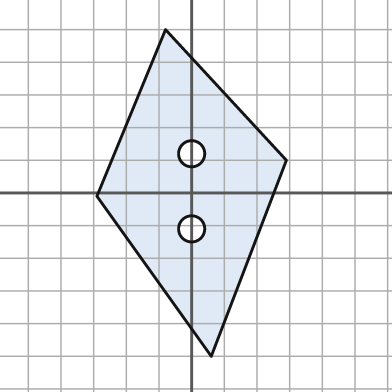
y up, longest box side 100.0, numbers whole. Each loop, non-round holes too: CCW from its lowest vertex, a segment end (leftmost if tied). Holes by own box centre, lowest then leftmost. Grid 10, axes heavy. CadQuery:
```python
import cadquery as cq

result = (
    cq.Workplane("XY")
    .moveTo(6.0, -50.0)
    .lineTo(29.0, 10.0)
    .lineTo(-8.0, 50.0)
    .lineTo(-29.0, -1.0)
    .close()
    .moveTo(0.0, -11.0)
    .circle(4.0)
    .moveTo(0.0, 12.0)
    .circle(4.0)
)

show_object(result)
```